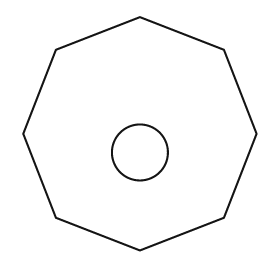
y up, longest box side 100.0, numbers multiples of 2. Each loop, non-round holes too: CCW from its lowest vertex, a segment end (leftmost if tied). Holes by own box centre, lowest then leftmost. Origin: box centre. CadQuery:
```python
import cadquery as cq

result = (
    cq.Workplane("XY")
    .moveTo(0.0, -50.0)
    .lineTo(36.0, -36.0)
    .lineTo(50.0, 0.0)
    .lineTo(36.0, 36.0)
    .lineTo(0.0, 50.0)
    .lineTo(-36.0, 36.0)
    .lineTo(-50.0, 0.0)
    .lineTo(-36.0, -36.0)
    .close()
    .moveTo(0.0, -8.0)
    .circle(12.0)
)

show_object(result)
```